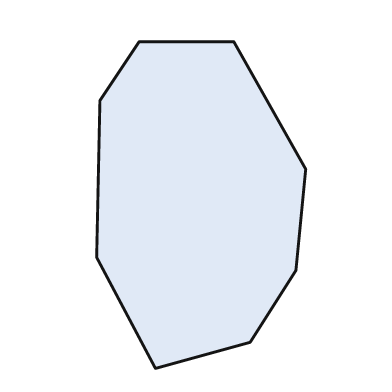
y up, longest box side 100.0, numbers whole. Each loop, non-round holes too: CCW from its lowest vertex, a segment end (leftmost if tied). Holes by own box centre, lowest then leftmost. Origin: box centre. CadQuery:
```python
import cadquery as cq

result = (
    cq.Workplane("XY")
    .moveTo(-14.0, -50.0)
    .lineTo(15.0, -42.0)
    .lineTo(29.0, -20.0)
    .lineTo(32.0, 11.0)
    .lineTo(10.0, 50.0)
    .lineTo(-19.0, 50.0)
    .lineTo(-31.0, 32.0)
    .lineTo(-32.0, -16.0)
    .close()
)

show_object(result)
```